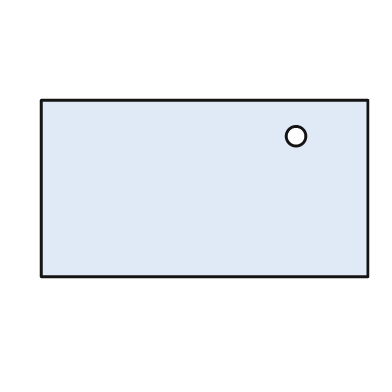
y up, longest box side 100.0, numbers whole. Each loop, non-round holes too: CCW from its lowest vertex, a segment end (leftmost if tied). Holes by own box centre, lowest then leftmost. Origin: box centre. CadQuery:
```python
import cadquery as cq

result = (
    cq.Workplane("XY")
    .moveTo(-50.0, -27.0)
    .lineTo(50.0, -27.0)
    .lineTo(50.0, 27.0)
    .lineTo(-50.0, 27.0)
    .close()
    .moveTo(28.0, 16.0)
    .circle(3.0)
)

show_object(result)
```